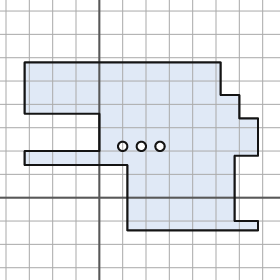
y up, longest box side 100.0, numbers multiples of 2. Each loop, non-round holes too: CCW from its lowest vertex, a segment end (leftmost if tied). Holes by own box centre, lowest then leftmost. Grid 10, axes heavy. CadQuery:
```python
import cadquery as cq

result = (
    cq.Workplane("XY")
    .moveTo(12.0, -14.0)
    .lineTo(68.0, -14.0)
    .lineTo(68.0, -10.0)
    .lineTo(58.0, -10.0)
    .lineTo(58.0, 18.0)
    .lineTo(68.0, 18.0)
    .lineTo(68.0, 34.0)
    .lineTo(60.0, 34.0)
    .lineTo(60.0, 44.0)
    .lineTo(52.0, 44.0)
    .lineTo(52.0, 58.0)
    .lineTo(-32.0, 58.0)
    .lineTo(-32.0, 36.0)
    .lineTo(0.0, 36.0)
    .lineTo(0.0, 20.0)
    .lineTo(-32.0, 20.0)
    .lineTo(-32.0, 14.0)
    .lineTo(12.0, 14.0)
    .close()
    .moveTo(10.0, 22.0)
    .circle(2.0)
    .moveTo(18.0, 22.0)
    .circle(2.0)
    .moveTo(26.0, 22.0)
    .circle(2.0)
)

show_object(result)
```